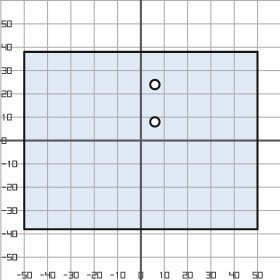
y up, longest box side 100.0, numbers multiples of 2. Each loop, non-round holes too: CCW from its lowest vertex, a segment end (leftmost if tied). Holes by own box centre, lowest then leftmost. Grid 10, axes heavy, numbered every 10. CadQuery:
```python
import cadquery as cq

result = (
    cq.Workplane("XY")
    .moveTo(-50.0, -38.0)
    .lineTo(50.0, -38.0)
    .lineTo(50.0, 38.0)
    .lineTo(-50.0, 38.0)
    .close()
    .moveTo(6.0, 8.0)
    .circle(2.0)
    .moveTo(6.0, 24.0)
    .circle(2.0)
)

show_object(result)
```